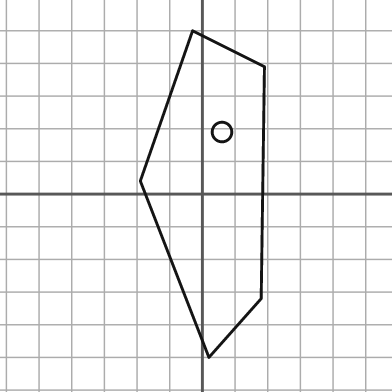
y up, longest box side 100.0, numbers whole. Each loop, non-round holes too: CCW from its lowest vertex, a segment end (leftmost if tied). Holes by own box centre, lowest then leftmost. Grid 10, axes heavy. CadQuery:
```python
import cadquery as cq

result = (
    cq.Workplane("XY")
    .moveTo(2.0, -50.0)
    .lineTo(18.0, -32.0)
    .lineTo(19.0, 39.0)
    .lineTo(-3.0, 50.0)
    .lineTo(-19.0, 4.0)
    .close()
    .moveTo(6.0, 19.0)
    .circle(3.0)
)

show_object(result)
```